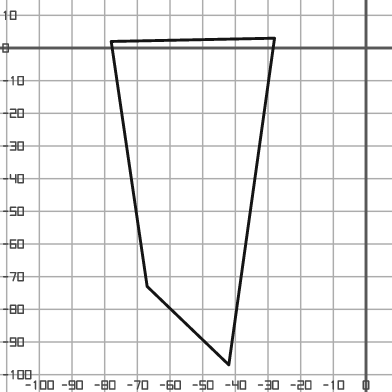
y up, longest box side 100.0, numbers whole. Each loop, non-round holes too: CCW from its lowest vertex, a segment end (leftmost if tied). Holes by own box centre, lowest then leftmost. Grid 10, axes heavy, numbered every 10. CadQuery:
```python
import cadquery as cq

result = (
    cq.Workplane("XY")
    .moveTo(-42.0, -97.0)
    .lineTo(-28.0, 3.0)
    .lineTo(-78.0, 2.0)
    .lineTo(-67.0, -73.0)
    .close()
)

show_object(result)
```